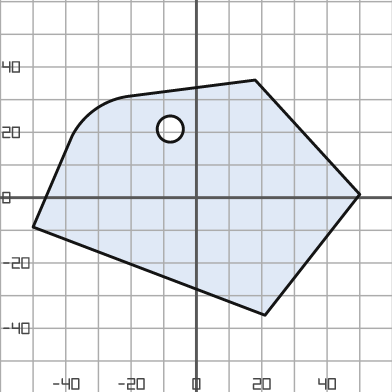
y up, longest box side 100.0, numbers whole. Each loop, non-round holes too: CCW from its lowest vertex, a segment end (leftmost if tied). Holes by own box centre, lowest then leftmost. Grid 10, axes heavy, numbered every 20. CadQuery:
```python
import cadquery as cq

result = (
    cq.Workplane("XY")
    .moveTo(21.0, -36.0)
    .lineTo(50.0, 1.0)
    .lineTo(18.0, 36.0)
    .lineTo(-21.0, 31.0)
    .threePointArc((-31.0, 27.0), (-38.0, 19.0))
    .lineTo(-50.0, -9.0)
    .close()
    .moveTo(-8.0, 21.0)
    .circle(4.0)
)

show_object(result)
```